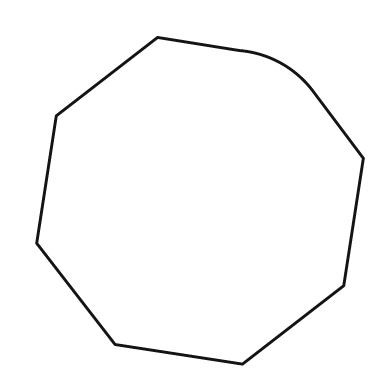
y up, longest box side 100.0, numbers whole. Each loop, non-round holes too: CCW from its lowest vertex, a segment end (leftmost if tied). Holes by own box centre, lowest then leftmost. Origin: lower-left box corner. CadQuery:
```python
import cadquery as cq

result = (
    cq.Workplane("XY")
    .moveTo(63.0, 0.0)
    .lineTo(94.0, 24.0)
    .lineTo(100.0, 63.0)
    .lineTo(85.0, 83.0)
    .threePointArc((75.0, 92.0), (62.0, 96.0))
    .lineTo(37.0, 100.0)
    .lineTo(6.0, 76.0)
    .lineTo(0.0, 37.0)
    .lineTo(24.0, 6.0)
    .close()
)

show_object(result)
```